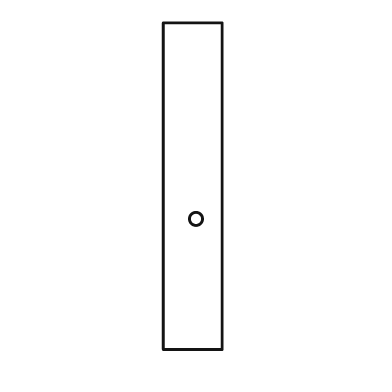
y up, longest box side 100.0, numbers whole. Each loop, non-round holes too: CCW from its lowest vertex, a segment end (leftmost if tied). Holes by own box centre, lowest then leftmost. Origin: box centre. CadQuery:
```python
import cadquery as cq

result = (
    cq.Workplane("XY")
    .moveTo(-9.0, -50.0)
    .lineTo(9.0, -50.0)
    .lineTo(9.0, 50.0)
    .lineTo(-9.0, 50.0)
    .close()
    .moveTo(1.0, -10.0)
    .circle(2.0)
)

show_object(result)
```